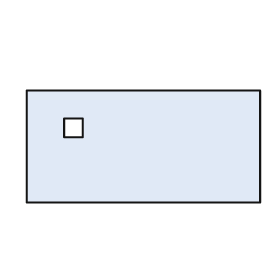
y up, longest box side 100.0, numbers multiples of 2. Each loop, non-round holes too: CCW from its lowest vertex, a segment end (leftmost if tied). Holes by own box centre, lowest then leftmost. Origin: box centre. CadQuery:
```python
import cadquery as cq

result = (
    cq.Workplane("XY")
    .moveTo(-50.0, -24.0)
    .lineTo(50.0, -24.0)
    .lineTo(50.0, 24.0)
    .lineTo(-50.0, 24.0)
    .close()
    .moveTo(-34.0, 4.0)
    .lineTo(-26.0, 4.0)
    .lineTo(-26.0, 12.0)
    .lineTo(-34.0, 12.0)
    .close()
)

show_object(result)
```